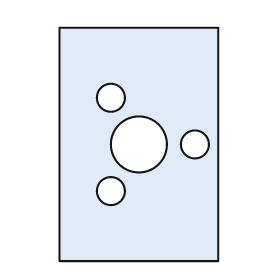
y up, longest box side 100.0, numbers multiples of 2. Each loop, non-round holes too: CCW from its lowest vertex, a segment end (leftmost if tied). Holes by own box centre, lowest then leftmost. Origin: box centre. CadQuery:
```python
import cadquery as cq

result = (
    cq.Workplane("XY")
    .moveTo(-34.0, -50.0)
    .lineTo(34.0, -50.0)
    .lineTo(34.0, 50.0)
    .lineTo(-34.0, 50.0)
    .close()
    .moveTo(-12.0, -20.0)
    .circle(6.0)
    .moveTo(0.0, 0.0)
    .circle(12.0)
    .moveTo(24.0, 0.0)
    .circle(6.0)
    .moveTo(-12.0, 20.0)
    .circle(6.0)
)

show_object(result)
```